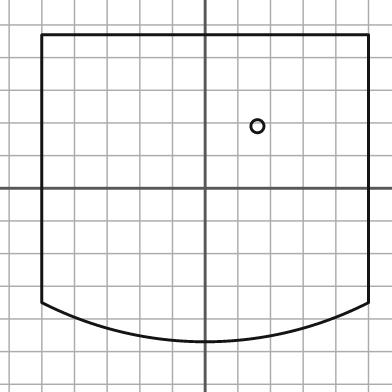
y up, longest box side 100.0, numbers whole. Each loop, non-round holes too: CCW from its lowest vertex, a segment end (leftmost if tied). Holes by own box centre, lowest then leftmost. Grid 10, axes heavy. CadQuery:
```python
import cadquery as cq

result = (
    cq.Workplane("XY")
    .moveTo(-50.0, -35.0)
    .threePointArc((0.0, -47.0), (50.0, -35.0))
    .lineTo(50.0, 47.0)
    .lineTo(-50.0, 47.0)
    .close()
    .moveTo(16.0, 19.0)
    .circle(2.0)
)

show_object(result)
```